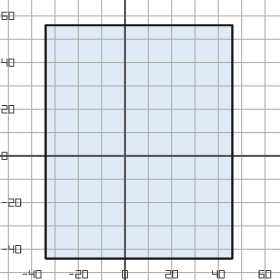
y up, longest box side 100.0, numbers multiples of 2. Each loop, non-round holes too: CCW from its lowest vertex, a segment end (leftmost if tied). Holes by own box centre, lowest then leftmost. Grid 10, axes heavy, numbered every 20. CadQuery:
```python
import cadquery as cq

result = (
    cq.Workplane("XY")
    .moveTo(-34.0, -44.0)
    .lineTo(46.0, -44.0)
    .lineTo(46.0, 56.0)
    .lineTo(-34.0, 56.0)
    .close()
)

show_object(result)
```